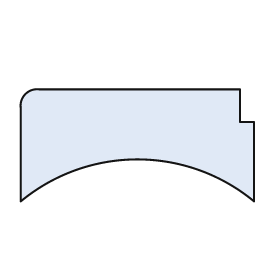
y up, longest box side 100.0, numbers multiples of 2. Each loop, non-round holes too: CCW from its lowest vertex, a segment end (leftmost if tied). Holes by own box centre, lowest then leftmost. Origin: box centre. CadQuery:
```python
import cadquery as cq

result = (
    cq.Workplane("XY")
    .moveTo(-50.0, -24.0)
    .threePointArc((0.0, -6.0), (50.0, -24.0))
    .lineTo(50.0, 10.0)
    .lineTo(44.0, 10.0)
    .lineTo(44.0, 24.0)
    .lineTo(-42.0, 24.0)
    .threePointArc((-48.0, 22.0), (-50.0, 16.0))
    .close()
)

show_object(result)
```